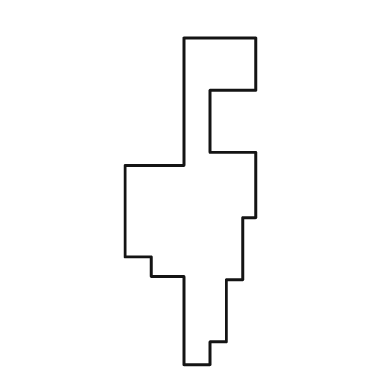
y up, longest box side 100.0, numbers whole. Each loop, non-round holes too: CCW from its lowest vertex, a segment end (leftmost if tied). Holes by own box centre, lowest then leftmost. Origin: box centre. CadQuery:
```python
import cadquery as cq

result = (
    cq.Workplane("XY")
    .moveTo(-2.0, -50.0)
    .lineTo(6.0, -50.0)
    .lineTo(6.0, -43.0)
    .lineTo(11.0, -43.0)
    .lineTo(11.0, -24.0)
    .lineTo(16.0, -24.0)
    .lineTo(16.0, -5.0)
    .lineTo(20.0, -5.0)
    .lineTo(20.0, 15.0)
    .lineTo(6.0, 15.0)
    .lineTo(6.0, 34.0)
    .lineTo(20.0, 34.0)
    .lineTo(20.0, 50.0)
    .lineTo(-2.0, 50.0)
    .lineTo(-2.0, 11.0)
    .lineTo(-20.0, 11.0)
    .lineTo(-20.0, -17.0)
    .lineTo(-12.0, -17.0)
    .lineTo(-12.0, -23.0)
    .lineTo(-2.0, -23.0)
    .close()
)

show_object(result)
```